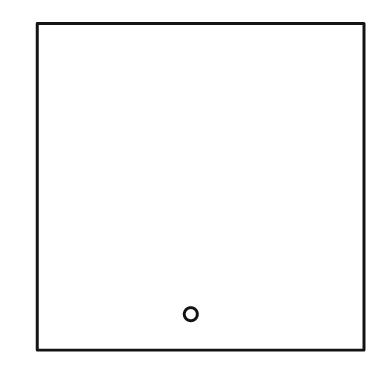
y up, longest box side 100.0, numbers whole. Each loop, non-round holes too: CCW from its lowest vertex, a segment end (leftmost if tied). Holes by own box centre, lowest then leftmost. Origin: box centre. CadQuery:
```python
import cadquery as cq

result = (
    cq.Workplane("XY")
    .moveTo(-50.0, -50.0)
    .lineTo(50.0, -50.0)
    .lineTo(50.0, 50.0)
    .lineTo(-50.0, 50.0)
    .close()
    .moveTo(-3.0, -39.0)
    .circle(2.0)
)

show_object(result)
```